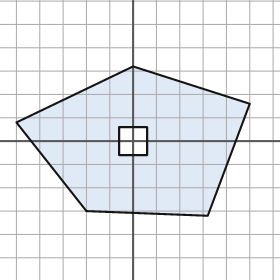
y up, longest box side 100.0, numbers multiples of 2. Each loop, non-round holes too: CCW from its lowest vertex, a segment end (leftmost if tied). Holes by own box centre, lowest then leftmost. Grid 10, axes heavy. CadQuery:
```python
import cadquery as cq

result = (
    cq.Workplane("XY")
    .moveTo(32.0, -32.0)
    .lineTo(50.0, 16.0)
    .lineTo(0.0, 32.0)
    .lineTo(-50.0, 8.0)
    .lineTo(-20.0, -30.0)
    .close()
    .moveTo(-6.0, -6.0)
    .lineTo(6.0, -6.0)
    .lineTo(6.0, 6.0)
    .lineTo(-6.0, 6.0)
    .close()
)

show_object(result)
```